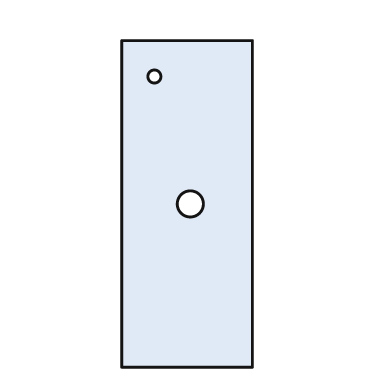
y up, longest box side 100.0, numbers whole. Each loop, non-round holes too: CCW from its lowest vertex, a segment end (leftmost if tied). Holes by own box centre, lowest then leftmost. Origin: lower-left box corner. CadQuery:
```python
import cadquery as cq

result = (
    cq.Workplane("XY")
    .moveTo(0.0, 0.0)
    .lineTo(40.0, 0.0)
    .lineTo(40.0, 100.0)
    .lineTo(0.0, 100.0)
    .close()
    .moveTo(21.0, 50.0)
    .circle(4.0)
    .moveTo(10.0, 89.0)
    .circle(2.0)
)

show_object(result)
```